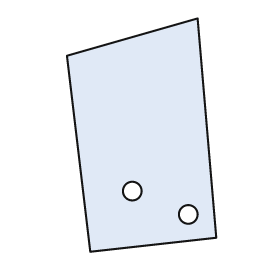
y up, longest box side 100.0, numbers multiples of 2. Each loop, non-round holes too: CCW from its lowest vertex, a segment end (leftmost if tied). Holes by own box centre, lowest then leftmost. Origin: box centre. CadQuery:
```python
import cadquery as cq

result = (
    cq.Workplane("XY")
    .moveTo(-22.0, -50.0)
    .lineTo(32.0, -44.0)
    .lineTo(24.0, 50.0)
    .lineTo(-32.0, 34.0)
    .close()
    .moveTo(20.0, -34.0)
    .circle(4.0)
    .moveTo(-4.0, -24.0)
    .circle(4.0)
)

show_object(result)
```